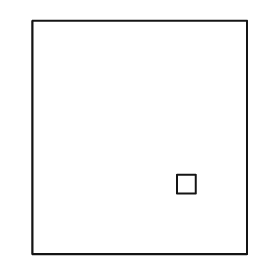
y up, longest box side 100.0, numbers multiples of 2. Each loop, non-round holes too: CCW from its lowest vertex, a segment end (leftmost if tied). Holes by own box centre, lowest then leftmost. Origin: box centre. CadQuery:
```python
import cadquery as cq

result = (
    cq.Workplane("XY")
    .moveTo(-46.0, -50.0)
    .lineTo(46.0, -50.0)
    .lineTo(46.0, 50.0)
    .lineTo(-46.0, 50.0)
    .close()
    .moveTo(16.0, -24.0)
    .lineTo(24.0, -24.0)
    .lineTo(24.0, -16.0)
    .lineTo(16.0, -16.0)
    .close()
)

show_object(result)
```